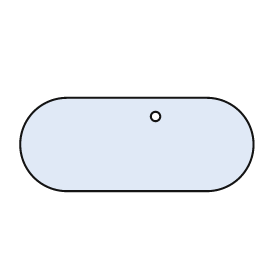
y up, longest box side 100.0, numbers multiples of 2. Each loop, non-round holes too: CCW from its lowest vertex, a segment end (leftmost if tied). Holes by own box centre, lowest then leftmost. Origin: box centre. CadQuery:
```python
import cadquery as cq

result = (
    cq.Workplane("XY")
    .moveTo(-30.0, -20.0)
    .lineTo(30.0, -20.0)
    .threePointArc((50.0, 0.0), (30.0, 20.0))
    .lineTo(-30.0, 20.0)
    .threePointArc((-50.0, 0.0), (-30.0, -20.0))
    .close()
    .moveTo(8.0, 12.0)
    .circle(2.0)
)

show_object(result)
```